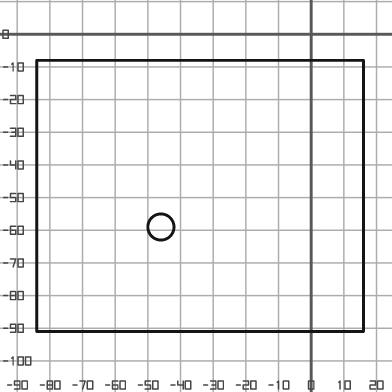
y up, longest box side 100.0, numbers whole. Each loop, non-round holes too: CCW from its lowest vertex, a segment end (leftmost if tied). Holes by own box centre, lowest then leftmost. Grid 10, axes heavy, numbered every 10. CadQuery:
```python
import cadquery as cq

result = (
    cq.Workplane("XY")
    .moveTo(-84.0, -91.0)
    .lineTo(16.0, -91.0)
    .lineTo(16.0, -8.0)
    .lineTo(-84.0, -8.0)
    .close()
    .moveTo(-46.0, -59.0)
    .circle(4.0)
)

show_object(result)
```